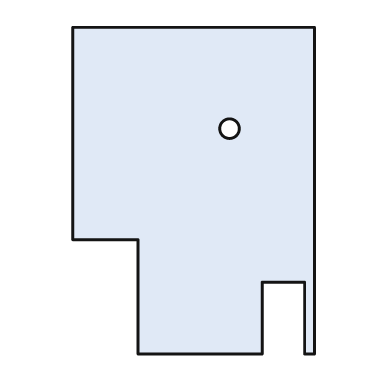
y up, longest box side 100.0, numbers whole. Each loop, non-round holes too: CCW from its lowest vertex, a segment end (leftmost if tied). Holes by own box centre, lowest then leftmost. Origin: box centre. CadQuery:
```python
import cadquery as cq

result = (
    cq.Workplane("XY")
    .moveTo(-17.0, -50.0)
    .lineTo(21.0, -50.0)
    .lineTo(21.0, -28.0)
    .lineTo(34.0, -28.0)
    .lineTo(34.0, -50.0)
    .lineTo(37.0, -50.0)
    .lineTo(37.0, 50.0)
    .lineTo(-37.0, 50.0)
    .lineTo(-37.0, -15.0)
    .lineTo(-17.0, -15.0)
    .close()
    .moveTo(11.0, 19.0)
    .circle(3.0)
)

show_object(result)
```